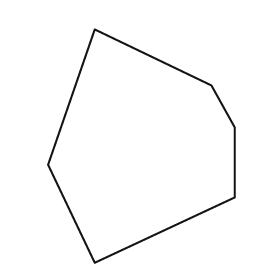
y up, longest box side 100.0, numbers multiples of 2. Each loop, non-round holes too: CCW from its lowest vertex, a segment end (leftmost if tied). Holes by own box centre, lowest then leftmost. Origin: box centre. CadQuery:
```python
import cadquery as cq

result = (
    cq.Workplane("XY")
    .moveTo(-20.0, -50.0)
    .lineTo(40.0, -22.0)
    .lineTo(40.0, 8.0)
    .lineTo(30.0, 26.0)
    .lineTo(-20.0, 50.0)
    .lineTo(-40.0, -8.0)
    .close()
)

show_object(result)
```